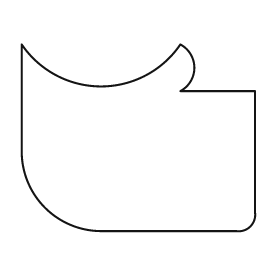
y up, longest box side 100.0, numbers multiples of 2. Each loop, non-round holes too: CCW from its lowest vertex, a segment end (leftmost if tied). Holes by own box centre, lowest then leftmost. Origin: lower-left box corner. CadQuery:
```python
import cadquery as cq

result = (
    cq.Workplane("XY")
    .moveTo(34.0, 0.0)
    .lineTo(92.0, 0.0)
    .threePointArc((98.0, 2.0), (100.0, 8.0))
    .lineTo(100.0, 60.0)
    .lineTo(68.0, 60.0)
    .threePointArc((74.0, 70.0), (68.0, 80.0))
    .threePointArc((34.0, 62.0), (0.0, 80.0))
    .lineTo(0.0, 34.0)
    .threePointArc((10.0, 10.0), (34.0, 0.0))
    .close()
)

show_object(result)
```